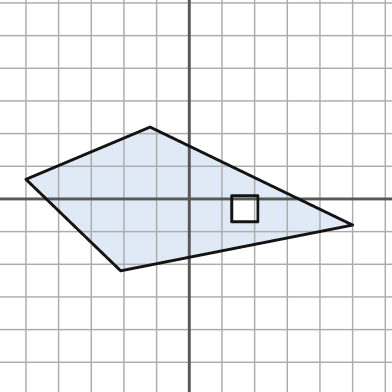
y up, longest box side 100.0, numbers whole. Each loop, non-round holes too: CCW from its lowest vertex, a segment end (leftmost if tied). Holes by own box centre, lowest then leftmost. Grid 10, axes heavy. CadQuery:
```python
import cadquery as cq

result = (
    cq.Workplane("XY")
    .moveTo(-21.0, -22.0)
    .lineTo(50.0, -8.0)
    .lineTo(-12.0, 22.0)
    .lineTo(-50.0, 6.0)
    .close()
    .moveTo(13.0, -7.0)
    .lineTo(21.0, -7.0)
    .lineTo(21.0, 1.0)
    .lineTo(13.0, 1.0)
    .close()
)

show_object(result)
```